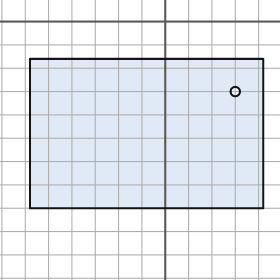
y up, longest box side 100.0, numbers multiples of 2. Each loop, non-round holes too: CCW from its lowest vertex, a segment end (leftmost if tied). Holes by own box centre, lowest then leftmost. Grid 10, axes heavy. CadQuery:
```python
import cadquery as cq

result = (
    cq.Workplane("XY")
    .moveTo(-58.0, -80.0)
    .lineTo(42.0, -80.0)
    .lineTo(42.0, -16.0)
    .lineTo(-58.0, -16.0)
    .close()
    .moveTo(30.0, -30.0)
    .circle(2.0)
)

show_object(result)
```